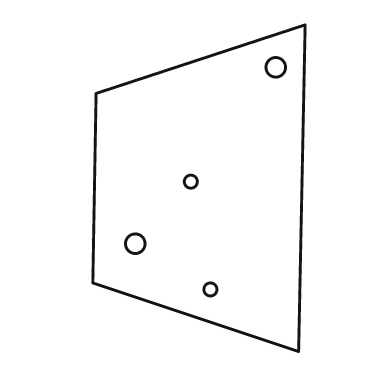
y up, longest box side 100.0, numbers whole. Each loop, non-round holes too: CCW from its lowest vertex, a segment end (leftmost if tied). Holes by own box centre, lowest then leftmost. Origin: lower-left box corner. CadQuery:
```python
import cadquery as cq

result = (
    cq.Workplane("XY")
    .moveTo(63.0, 0.0)
    .lineTo(65.0, 100.0)
    .lineTo(1.0, 79.0)
    .lineTo(0.0, 21.0)
    .close()
    .moveTo(36.0, 19.0)
    .circle(2.0)
    .moveTo(13.0, 33.0)
    .circle(3.0)
    .moveTo(30.0, 52.0)
    .circle(2.0)
    .moveTo(56.0, 87.0)
    .circle(3.0)
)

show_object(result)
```